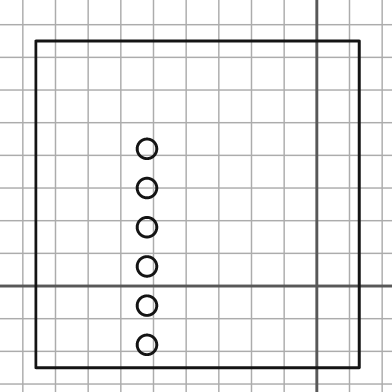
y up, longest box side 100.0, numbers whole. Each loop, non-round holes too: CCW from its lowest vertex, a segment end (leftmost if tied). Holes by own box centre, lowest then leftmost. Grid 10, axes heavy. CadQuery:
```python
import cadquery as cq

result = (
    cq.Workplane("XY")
    .moveTo(-86.0, -25.0)
    .lineTo(13.0, -25.0)
    .lineTo(13.0, 75.0)
    .lineTo(-86.0, 75.0)
    .close()
    .moveTo(-52.0, -18.0)
    .circle(3.0)
    .moveTo(-52.0, -6.0)
    .circle(3.0)
    .moveTo(-52.0, 6.0)
    .circle(3.0)
    .moveTo(-52.0, 18.0)
    .circle(3.0)
    .moveTo(-52.0, 30.0)
    .circle(3.0)
    .moveTo(-52.0, 42.0)
    .circle(3.0)
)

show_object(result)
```